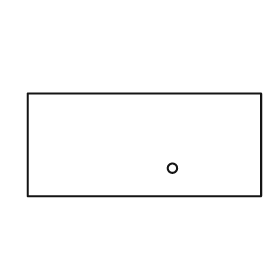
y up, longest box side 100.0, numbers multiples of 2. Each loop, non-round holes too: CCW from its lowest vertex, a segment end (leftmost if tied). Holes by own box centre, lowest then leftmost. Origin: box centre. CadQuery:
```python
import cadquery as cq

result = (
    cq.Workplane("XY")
    .moveTo(-50.0, -22.0)
    .lineTo(50.0, -22.0)
    .lineTo(50.0, 22.0)
    .lineTo(-50.0, 22.0)
    .close()
    .moveTo(12.0, -10.0)
    .circle(2.0)
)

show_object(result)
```